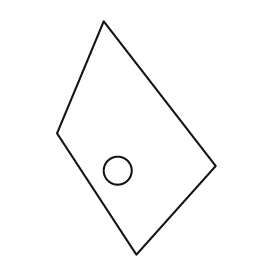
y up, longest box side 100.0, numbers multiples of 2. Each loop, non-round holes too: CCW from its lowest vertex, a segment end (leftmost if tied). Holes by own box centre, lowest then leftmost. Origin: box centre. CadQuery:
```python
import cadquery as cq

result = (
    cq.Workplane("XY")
    .moveTo(0.0, -50.0)
    .lineTo(34.0, -12.0)
    .lineTo(-14.0, 50.0)
    .lineTo(-34.0, 2.0)
    .close()
    .moveTo(-8.0, -14.0)
    .circle(6.0)
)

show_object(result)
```